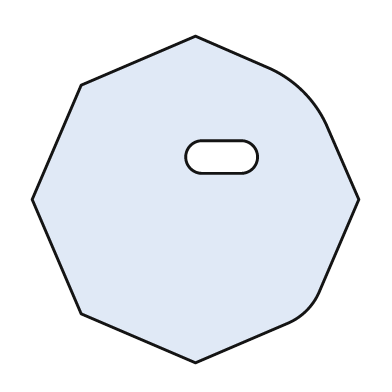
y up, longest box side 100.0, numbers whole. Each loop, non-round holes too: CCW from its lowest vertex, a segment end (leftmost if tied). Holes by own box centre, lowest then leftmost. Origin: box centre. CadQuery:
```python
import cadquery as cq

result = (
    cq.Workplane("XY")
    .moveTo(0.0, -50.0)
    .lineTo(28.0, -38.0)
    .threePointArc((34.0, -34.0), (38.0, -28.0))
    .lineTo(50.0, 0.0)
    .lineTo(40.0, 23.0)
    .threePointArc((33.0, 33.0), (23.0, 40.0))
    .lineTo(0.0, 50.0)
    .lineTo(-35.0, 35.0)
    .lineTo(-50.0, 0.0)
    .lineTo(-35.0, -35.0)
    .close()
    .moveTo(2.0, 8.0)
    .lineTo(14.0, 8.0)
    .threePointArc((19.0, 13.0), (14.0, 18.0))
    .lineTo(2.0, 18.0)
    .threePointArc((-3.0, 13.0), (2.0, 8.0))
    .close()
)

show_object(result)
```